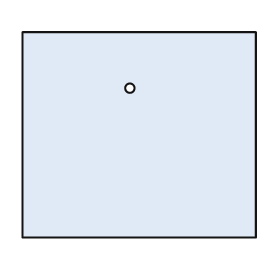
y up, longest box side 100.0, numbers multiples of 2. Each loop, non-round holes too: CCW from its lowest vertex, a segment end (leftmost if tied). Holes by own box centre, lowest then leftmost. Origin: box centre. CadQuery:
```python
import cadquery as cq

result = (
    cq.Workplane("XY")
    .moveTo(-50.0, -44.0)
    .lineTo(50.0, -44.0)
    .lineTo(50.0, 44.0)
    .lineTo(-50.0, 44.0)
    .close()
    .moveTo(-4.0, 20.0)
    .circle(2.0)
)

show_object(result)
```